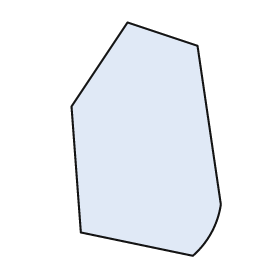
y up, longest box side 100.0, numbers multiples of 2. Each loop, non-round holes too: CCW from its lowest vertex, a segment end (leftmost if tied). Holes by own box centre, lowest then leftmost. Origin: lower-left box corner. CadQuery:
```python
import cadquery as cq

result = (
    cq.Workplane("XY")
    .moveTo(52.0, 0.0)
    .threePointArc((60.0, 10.0), (64.0, 22.0))
    .lineTo(54.0, 90.0)
    .lineTo(24.0, 100.0)
    .lineTo(0.0, 64.0)
    .lineTo(4.0, 10.0)
    .close()
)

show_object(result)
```